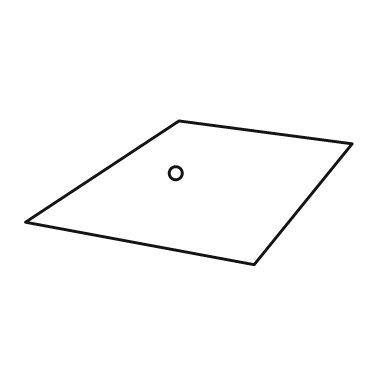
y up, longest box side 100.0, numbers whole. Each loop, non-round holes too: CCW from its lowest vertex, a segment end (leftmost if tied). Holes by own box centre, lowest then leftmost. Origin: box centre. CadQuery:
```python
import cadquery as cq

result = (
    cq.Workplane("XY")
    .moveTo(20.0, -22.0)
    .lineTo(50.0, 15.0)
    .lineTo(-3.0, 22.0)
    .lineTo(-50.0, -9.0)
    .close()
    .moveTo(-4.0, 6.0)
    .circle(2.0)
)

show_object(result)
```